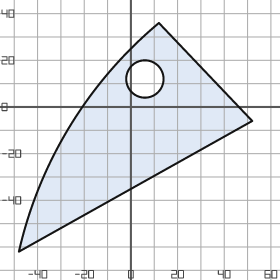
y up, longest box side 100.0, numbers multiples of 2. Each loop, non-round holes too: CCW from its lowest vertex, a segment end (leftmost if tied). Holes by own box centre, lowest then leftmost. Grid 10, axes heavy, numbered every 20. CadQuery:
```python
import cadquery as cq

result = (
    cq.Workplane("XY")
    .moveTo(-48.0, -62.0)
    .lineTo(52.0, -6.0)
    .lineTo(12.0, 36.0)
    .threePointArc((-26.0, -8.0), (-48.0, -62.0))
    .close()
    .moveTo(6.0, 12.0)
    .circle(8.0)
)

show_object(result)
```